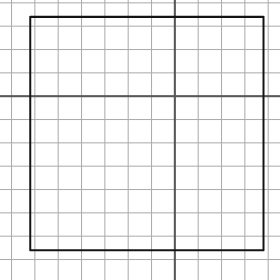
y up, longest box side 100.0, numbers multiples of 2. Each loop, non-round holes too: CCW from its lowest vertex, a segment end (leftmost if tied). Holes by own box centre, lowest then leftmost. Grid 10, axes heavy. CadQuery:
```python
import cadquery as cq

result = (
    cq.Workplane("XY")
    .moveTo(-62.0, -66.0)
    .lineTo(38.0, -66.0)
    .lineTo(38.0, 34.0)
    .lineTo(-62.0, 34.0)
    .close()
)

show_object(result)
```